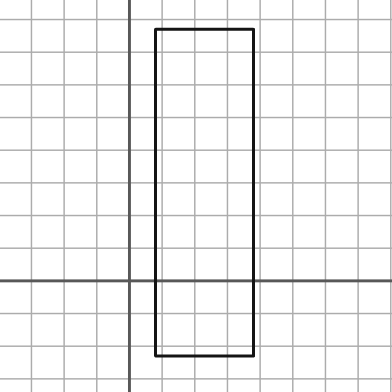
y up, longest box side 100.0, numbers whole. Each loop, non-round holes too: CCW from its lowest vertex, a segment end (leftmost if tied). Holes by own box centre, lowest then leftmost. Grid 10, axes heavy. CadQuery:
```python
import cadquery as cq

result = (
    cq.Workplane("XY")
    .moveTo(8.0, -23.0)
    .lineTo(38.0, -23.0)
    .lineTo(38.0, 77.0)
    .lineTo(8.0, 77.0)
    .close()
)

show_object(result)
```